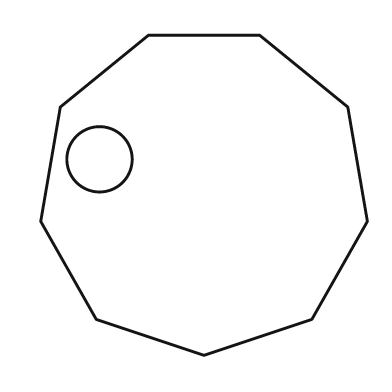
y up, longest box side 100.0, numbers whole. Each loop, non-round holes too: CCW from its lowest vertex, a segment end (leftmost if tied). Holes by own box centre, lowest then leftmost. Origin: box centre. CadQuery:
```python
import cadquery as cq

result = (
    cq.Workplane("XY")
    .moveTo(0.0, -49.0)
    .lineTo(33.0, -38.0)
    .lineTo(50.0, -8.0)
    .lineTo(44.0, 27.0)
    .lineTo(17.0, 49.0)
    .lineTo(-17.0, 49.0)
    .lineTo(-44.0, 27.0)
    .lineTo(-50.0, -8.0)
    .lineTo(-33.0, -38.0)
    .close()
    .moveTo(-32.0, 11.0)
    .circle(10.0)
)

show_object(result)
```